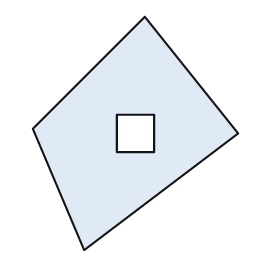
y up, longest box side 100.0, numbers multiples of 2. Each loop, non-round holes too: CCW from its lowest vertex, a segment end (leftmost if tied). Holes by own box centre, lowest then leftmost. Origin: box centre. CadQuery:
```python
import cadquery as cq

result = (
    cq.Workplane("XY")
    .moveTo(-22.0, -50.0)
    .lineTo(44.0, 0.0)
    .lineTo(4.0, 50.0)
    .lineTo(-44.0, 2.0)
    .close()
    .moveTo(-8.0, -8.0)
    .lineTo(8.0, -8.0)
    .lineTo(8.0, 8.0)
    .lineTo(-8.0, 8.0)
    .close()
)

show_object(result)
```